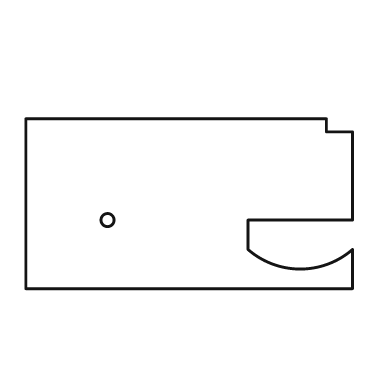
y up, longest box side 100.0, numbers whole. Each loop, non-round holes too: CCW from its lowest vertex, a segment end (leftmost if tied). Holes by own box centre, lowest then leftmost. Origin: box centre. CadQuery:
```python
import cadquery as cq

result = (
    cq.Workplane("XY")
    .moveTo(-50.0, -26.0)
    .lineTo(50.0, -26.0)
    .lineTo(50.0, -14.0)
    .threePointArc((34.0, -20.0), (18.0, -14.0))
    .lineTo(18.0, -5.0)
    .lineTo(50.0, -5.0)
    .lineTo(50.0, 22.0)
    .lineTo(42.0, 22.0)
    .lineTo(42.0, 26.0)
    .lineTo(-50.0, 26.0)
    .close()
    .moveTo(-25.0, -5.0)
    .circle(2.0)
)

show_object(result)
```